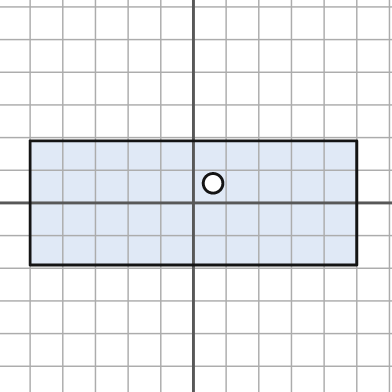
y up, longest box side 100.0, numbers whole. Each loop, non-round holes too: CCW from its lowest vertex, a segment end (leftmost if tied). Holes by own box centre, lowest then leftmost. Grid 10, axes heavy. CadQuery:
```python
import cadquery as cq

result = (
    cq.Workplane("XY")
    .moveTo(-50.0, -19.0)
    .lineTo(50.0, -19.0)
    .lineTo(50.0, 19.0)
    .lineTo(-50.0, 19.0)
    .close()
    .moveTo(6.0, 6.0)
    .circle(3.0)
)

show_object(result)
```